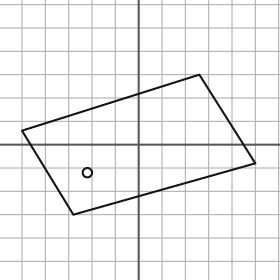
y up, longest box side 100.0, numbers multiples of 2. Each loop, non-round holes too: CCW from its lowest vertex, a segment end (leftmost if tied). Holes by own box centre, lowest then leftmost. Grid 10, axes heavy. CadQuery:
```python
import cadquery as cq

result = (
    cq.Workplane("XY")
    .moveTo(-28.0, -30.0)
    .lineTo(50.0, -8.0)
    .lineTo(26.0, 30.0)
    .lineTo(-50.0, 6.0)
    .close()
    .moveTo(-22.0, -12.0)
    .circle(2.0)
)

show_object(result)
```